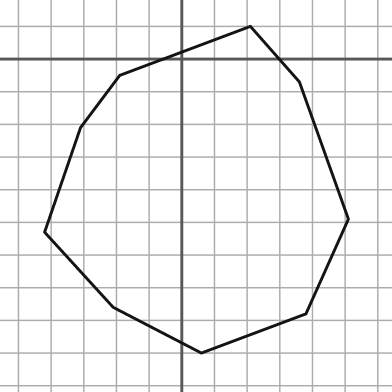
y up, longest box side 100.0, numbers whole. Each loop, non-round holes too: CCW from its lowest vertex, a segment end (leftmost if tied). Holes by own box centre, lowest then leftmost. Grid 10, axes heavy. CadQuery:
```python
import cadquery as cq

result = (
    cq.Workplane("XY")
    .moveTo(6.0, -90.0)
    .lineTo(38.0, -78.0)
    .lineTo(51.0, -49.0)
    .lineTo(36.0, -7.0)
    .lineTo(21.0, 10.0)
    .lineTo(-19.0, -5.0)
    .lineTo(-31.0, -21.0)
    .lineTo(-42.0, -53.0)
    .lineTo(-21.0, -76.0)
    .close()
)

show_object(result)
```